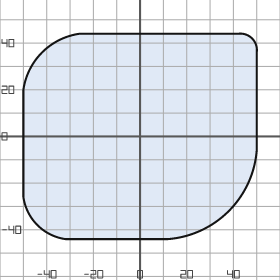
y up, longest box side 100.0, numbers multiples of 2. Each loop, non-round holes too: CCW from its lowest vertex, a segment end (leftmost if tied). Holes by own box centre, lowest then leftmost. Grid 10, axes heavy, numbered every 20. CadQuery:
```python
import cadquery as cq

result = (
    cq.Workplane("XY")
    .moveTo(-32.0, -44.0)
    .lineTo(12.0, -44.0)
    .threePointArc((38.0, -32.0), (50.0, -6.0))
    .lineTo(50.0, 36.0)
    .threePointArc((48.0, 42.0), (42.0, 44.0))
    .lineTo(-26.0, 44.0)
    .threePointArc((-42.0, 36.0), (-50.0, 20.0))
    .lineTo(-50.0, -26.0)
    .threePointArc((-44.0, -38.0), (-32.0, -44.0))
    .close()
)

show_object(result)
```